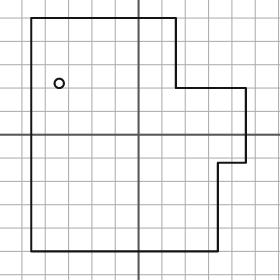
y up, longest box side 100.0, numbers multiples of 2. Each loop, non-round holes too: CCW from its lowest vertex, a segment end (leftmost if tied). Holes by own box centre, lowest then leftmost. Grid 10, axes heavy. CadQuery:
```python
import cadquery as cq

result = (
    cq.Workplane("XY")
    .moveTo(-46.0, -50.0)
    .lineTo(34.0, -50.0)
    .lineTo(34.0, -12.0)
    .lineTo(46.0, -12.0)
    .lineTo(46.0, 20.0)
    .lineTo(16.0, 20.0)
    .lineTo(16.0, 50.0)
    .lineTo(-46.0, 50.0)
    .close()
    .moveTo(-34.0, 22.0)
    .circle(2.0)
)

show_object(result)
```